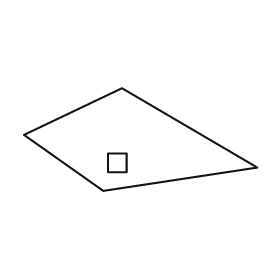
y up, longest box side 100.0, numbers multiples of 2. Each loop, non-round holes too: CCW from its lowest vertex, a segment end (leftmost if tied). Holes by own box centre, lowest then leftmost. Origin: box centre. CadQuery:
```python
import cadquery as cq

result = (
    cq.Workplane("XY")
    .moveTo(-16.0, -22.0)
    .lineTo(50.0, -12.0)
    .lineTo(-8.0, 22.0)
    .lineTo(-50.0, 2.0)
    .close()
    .moveTo(-14.0, -14.0)
    .lineTo(-6.0, -14.0)
    .lineTo(-6.0, -6.0)
    .lineTo(-14.0, -6.0)
    .close()
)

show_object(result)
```